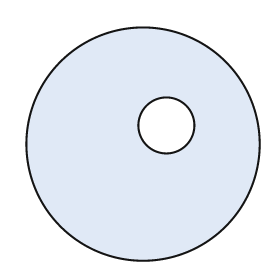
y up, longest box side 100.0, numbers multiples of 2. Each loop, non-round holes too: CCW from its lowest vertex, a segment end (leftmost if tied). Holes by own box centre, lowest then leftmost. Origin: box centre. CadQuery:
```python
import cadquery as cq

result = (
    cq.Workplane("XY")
    .moveTo(0.0, 0.0)
    .circle(50.0)
    .moveTo(10.0, 8.0)
    .circle(12.0)
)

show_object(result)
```